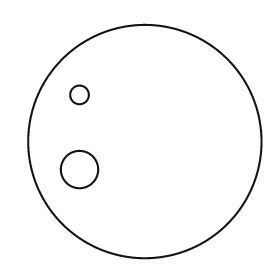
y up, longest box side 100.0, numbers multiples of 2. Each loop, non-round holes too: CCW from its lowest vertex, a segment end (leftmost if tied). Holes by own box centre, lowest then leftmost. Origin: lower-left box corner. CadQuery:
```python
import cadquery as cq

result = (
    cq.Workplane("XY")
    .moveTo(50.0, 50.0)
    .circle(50.0)
    .moveTo(22.0, 38.0)
    .circle(8.0)
    .moveTo(22.0, 70.0)
    .circle(4.0)
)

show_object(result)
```